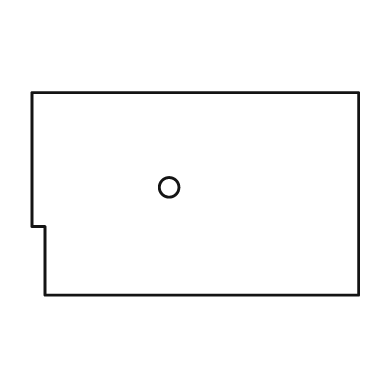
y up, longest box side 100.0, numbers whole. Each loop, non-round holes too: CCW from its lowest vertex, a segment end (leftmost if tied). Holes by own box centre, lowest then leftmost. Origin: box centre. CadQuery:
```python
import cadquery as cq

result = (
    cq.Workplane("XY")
    .moveTo(-46.0, -31.0)
    .lineTo(50.0, -31.0)
    .lineTo(50.0, 31.0)
    .lineTo(-50.0, 31.0)
    .lineTo(-50.0, -10.0)
    .lineTo(-46.0, -10.0)
    .close()
    .moveTo(-8.0, 2.0)
    .circle(3.0)
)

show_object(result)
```